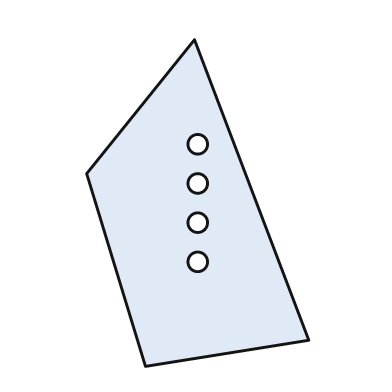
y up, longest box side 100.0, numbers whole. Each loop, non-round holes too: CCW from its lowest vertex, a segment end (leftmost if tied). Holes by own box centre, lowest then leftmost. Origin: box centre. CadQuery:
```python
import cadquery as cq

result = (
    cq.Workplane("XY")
    .moveTo(-16.0, -50.0)
    .lineTo(34.0, -42.0)
    .lineTo(-1.0, 50.0)
    .lineTo(-34.0, 9.0)
    .close()
    .moveTo(0.0, -18.0)
    .circle(3.0)
    .moveTo(0.0, -6.0)
    .circle(3.0)
    .moveTo(0.0, 6.0)
    .circle(3.0)
    .moveTo(0.0, 18.0)
    .circle(3.0)
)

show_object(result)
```